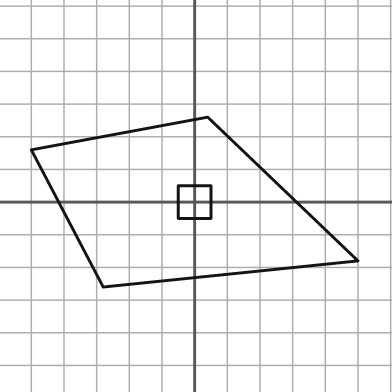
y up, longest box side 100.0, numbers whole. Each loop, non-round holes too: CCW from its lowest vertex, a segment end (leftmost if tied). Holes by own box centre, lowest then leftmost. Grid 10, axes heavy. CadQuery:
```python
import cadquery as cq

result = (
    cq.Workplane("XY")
    .moveTo(-28.0, -26.0)
    .lineTo(50.0, -18.0)
    .lineTo(4.0, 26.0)
    .lineTo(-50.0, 16.0)
    .close()
    .moveTo(-5.0, -5.0)
    .lineTo(5.0, -5.0)
    .lineTo(5.0, 5.0)
    .lineTo(-5.0, 5.0)
    .close()
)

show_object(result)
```